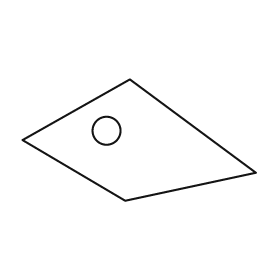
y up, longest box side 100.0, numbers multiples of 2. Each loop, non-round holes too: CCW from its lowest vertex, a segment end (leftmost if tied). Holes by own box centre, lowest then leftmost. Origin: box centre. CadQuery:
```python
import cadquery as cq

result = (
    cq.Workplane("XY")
    .moveTo(-6.0, -26.0)
    .lineTo(50.0, -14.0)
    .lineTo(-4.0, 26.0)
    .lineTo(-50.0, 0.0)
    .close()
    .moveTo(-14.0, 4.0)
    .circle(6.0)
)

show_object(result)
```